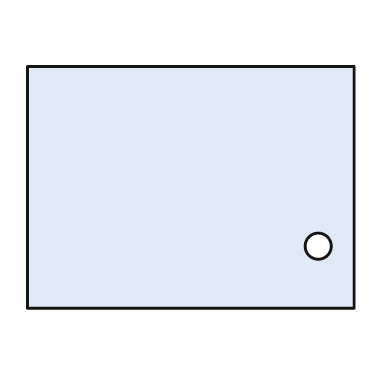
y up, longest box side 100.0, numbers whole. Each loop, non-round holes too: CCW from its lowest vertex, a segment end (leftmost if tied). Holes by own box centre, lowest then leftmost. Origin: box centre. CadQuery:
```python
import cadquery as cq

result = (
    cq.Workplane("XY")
    .moveTo(-50.0, -37.0)
    .lineTo(50.0, -37.0)
    .lineTo(50.0, 37.0)
    .lineTo(-50.0, 37.0)
    .close()
    .moveTo(39.0, -18.0)
    .circle(4.0)
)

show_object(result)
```